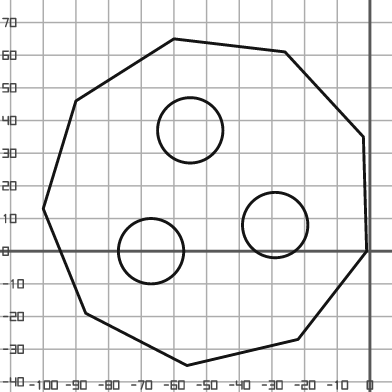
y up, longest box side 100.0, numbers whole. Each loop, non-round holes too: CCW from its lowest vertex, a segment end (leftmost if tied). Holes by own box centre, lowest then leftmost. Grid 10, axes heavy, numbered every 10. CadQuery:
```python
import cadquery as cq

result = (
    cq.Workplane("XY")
    .moveTo(-56.0, -35.0)
    .lineTo(-22.0, -27.0)
    .lineTo(-1.0, 0.0)
    .lineTo(-2.0, 35.0)
    .lineTo(-26.0, 61.0)
    .lineTo(-60.0, 65.0)
    .lineTo(-90.0, 46.0)
    .lineTo(-100.0, 13.0)
    .lineTo(-87.0, -19.0)
    .close()
    .moveTo(-67.0, 0.0)
    .circle(10.0)
    .moveTo(-29.0, 8.0)
    .circle(10.0)
    .moveTo(-55.0, 37.0)
    .circle(10.0)
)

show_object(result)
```